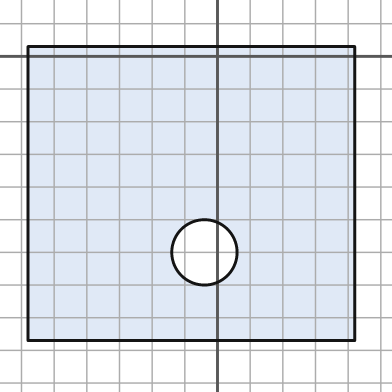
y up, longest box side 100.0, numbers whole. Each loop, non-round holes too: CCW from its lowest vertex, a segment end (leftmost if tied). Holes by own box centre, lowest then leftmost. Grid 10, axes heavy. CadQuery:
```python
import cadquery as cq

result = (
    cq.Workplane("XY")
    .moveTo(-58.0, -87.0)
    .lineTo(42.0, -87.0)
    .lineTo(42.0, 3.0)
    .lineTo(-58.0, 3.0)
    .close()
    .moveTo(-4.0, -60.0)
    .circle(10.0)
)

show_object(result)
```